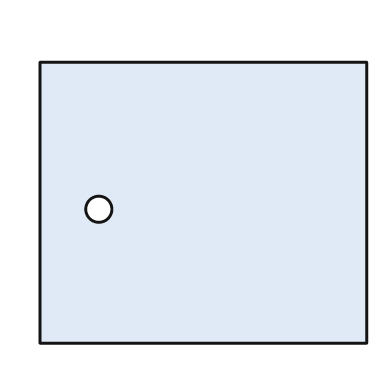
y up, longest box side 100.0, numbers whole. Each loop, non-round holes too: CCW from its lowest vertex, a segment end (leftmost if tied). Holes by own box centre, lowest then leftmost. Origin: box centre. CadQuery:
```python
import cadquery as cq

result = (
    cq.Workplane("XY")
    .moveTo(-50.0, -43.0)
    .lineTo(50.0, -43.0)
    .lineTo(50.0, 43.0)
    .lineTo(-50.0, 43.0)
    .close()
    .moveTo(-32.0, -2.0)
    .circle(4.0)
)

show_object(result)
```